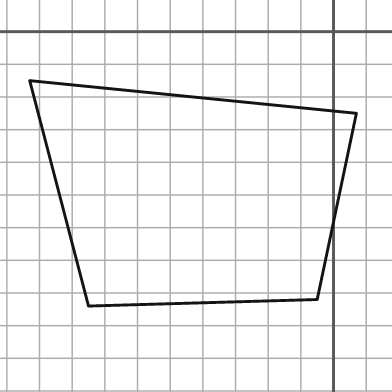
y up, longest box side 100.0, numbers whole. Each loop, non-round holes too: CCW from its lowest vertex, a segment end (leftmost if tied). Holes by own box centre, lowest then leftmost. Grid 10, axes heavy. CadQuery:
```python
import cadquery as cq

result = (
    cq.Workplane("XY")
    .moveTo(-75.0, -84.0)
    .lineTo(-5.0, -82.0)
    .lineTo(7.0, -25.0)
    .lineTo(-93.0, -15.0)
    .close()
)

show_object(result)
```